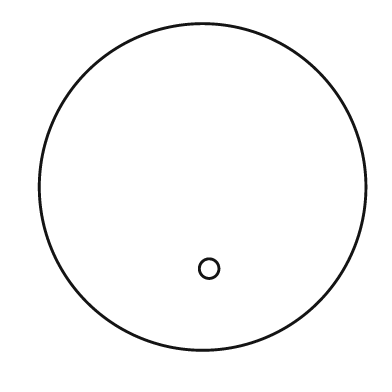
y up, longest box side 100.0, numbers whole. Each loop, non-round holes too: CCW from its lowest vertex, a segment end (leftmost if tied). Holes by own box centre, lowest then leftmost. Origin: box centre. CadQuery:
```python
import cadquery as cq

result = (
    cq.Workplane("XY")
    .moveTo(0.0, 0.0)
    .circle(50.0)
    .moveTo(2.0, -25.0)
    .circle(3.0)
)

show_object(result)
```